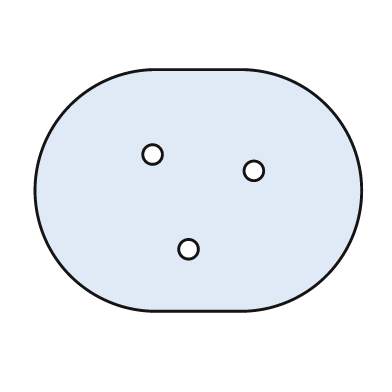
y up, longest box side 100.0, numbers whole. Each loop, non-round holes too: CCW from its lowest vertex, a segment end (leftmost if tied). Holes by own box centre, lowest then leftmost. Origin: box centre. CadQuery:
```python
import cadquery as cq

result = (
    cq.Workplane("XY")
    .moveTo(-13.0, -37.0)
    .lineTo(13.0, -37.0)
    .threePointArc((50.0, 0.0), (13.0, 37.0))
    .lineTo(-13.0, 37.0)
    .threePointArc((-50.0, 0.0), (-13.0, -37.0))
    .close()
    .moveTo(-3.0, -18.0)
    .circle(3.0)
    .moveTo(17.0, 6.0)
    .circle(3.0)
    .moveTo(-14.0, 11.0)
    .circle(3.0)
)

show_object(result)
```